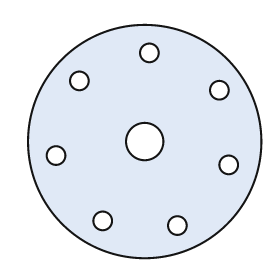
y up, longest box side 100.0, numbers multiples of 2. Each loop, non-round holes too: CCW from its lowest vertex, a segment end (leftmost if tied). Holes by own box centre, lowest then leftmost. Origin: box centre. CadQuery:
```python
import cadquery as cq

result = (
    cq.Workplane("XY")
    .moveTo(0.0, 0.0)
    .circle(50.0)
    .moveTo(14.0, -36.0)
    .circle(4.0)
    .moveTo(-18.0, -34.0)
    .circle(4.0)
    .moveTo(36.0, -10.0)
    .circle(4.0)
    .moveTo(-38.0, -6.0)
    .circle(4.0)
    .moveTo(0.0, 0.0)
    .circle(8.0)
    .moveTo(32.0, 22.0)
    .circle(4.0)
    .moveTo(-28.0, 26.0)
    .circle(4.0)
    .moveTo(2.0, 38.0)
    .circle(4.0)
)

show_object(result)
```